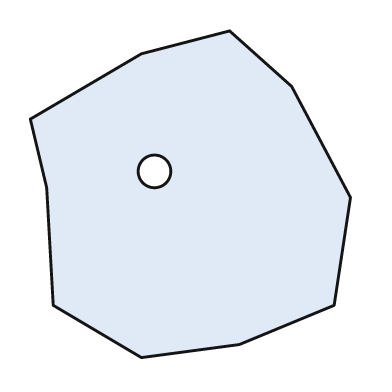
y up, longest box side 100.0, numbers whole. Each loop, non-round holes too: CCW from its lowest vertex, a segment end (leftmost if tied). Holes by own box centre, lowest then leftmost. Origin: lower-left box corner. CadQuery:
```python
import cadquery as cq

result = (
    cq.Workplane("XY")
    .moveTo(34.0, 0.0)
    .lineTo(64.0, 4.0)
    .lineTo(93.0, 16.0)
    .lineTo(98.0, 49.0)
    .lineTo(80.0, 83.0)
    .lineTo(61.0, 100.0)
    .lineTo(34.0, 93.0)
    .lineTo(0.0, 73.0)
    .lineTo(5.0, 52.0)
    .lineTo(7.0, 16.0)
    .close()
    .moveTo(38.0, 57.0)
    .circle(5.0)
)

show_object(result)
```